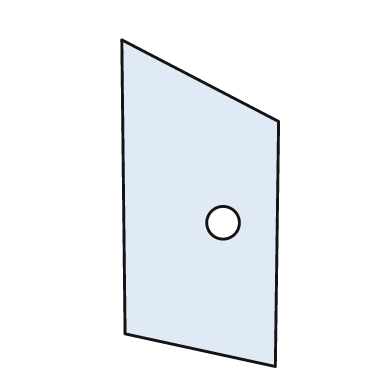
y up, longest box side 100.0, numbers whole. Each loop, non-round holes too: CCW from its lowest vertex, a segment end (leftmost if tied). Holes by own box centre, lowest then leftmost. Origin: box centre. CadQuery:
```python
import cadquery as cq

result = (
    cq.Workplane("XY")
    .moveTo(23.0, -50.0)
    .lineTo(24.0, 25.0)
    .lineTo(-24.0, 50.0)
    .lineTo(-23.0, -40.0)
    .close()
    .moveTo(7.0, -6.0)
    .circle(5.0)
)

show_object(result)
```